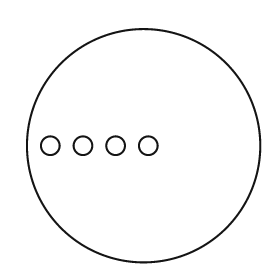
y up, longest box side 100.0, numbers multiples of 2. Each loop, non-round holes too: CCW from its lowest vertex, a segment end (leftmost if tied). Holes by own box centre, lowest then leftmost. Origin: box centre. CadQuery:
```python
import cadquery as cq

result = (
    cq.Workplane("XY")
    .moveTo(0.0, 0.0)
    .circle(50.0)
    .moveTo(-40.0, 0.0)
    .circle(4.0)
    .moveTo(-26.0, 0.0)
    .circle(4.0)
    .moveTo(-12.0, 0.0)
    .circle(4.0)
    .moveTo(2.0, 0.0)
    .circle(4.0)
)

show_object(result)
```